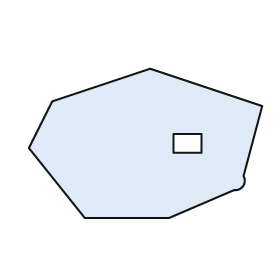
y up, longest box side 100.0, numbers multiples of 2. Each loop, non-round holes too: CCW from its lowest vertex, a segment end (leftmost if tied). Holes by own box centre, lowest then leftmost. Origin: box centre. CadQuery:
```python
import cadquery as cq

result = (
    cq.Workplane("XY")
    .moveTo(-26.0, -32.0)
    .lineTo(10.0, -32.0)
    .lineTo(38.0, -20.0)
    .threePointArc((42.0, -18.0), (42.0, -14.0))
    .lineTo(50.0, 16.0)
    .lineTo(2.0, 32.0)
    .lineTo(-40.0, 18.0)
    .lineTo(-50.0, -2.0)
    .close()
    .moveTo(12.0, -4.0)
    .lineTo(24.0, -4.0)
    .lineTo(24.0, 4.0)
    .lineTo(12.0, 4.0)
    .close()
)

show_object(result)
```